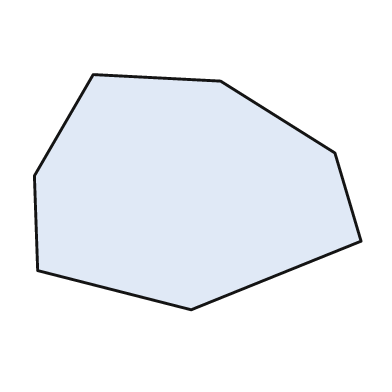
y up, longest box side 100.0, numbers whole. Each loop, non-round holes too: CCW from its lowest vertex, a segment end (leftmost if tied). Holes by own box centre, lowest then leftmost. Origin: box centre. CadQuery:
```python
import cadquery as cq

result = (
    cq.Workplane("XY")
    .moveTo(-2.0, -36.0)
    .lineTo(50.0, -15.0)
    .lineTo(42.0, 12.0)
    .lineTo(7.0, 34.0)
    .lineTo(-32.0, 36.0)
    .lineTo(-50.0, 5.0)
    .lineTo(-49.0, -24.0)
    .close()
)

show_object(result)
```